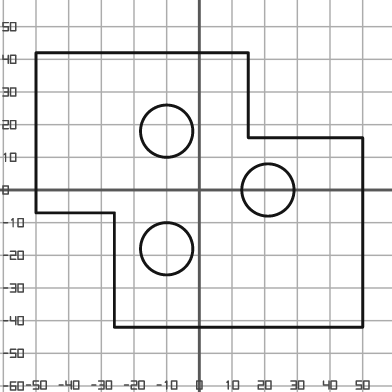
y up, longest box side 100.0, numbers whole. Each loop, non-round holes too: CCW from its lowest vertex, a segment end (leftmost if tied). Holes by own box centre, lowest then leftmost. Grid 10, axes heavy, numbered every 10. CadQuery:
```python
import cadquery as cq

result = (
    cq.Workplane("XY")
    .moveTo(-26.0, -42.0)
    .lineTo(50.0, -42.0)
    .lineTo(50.0, 16.0)
    .lineTo(15.0, 16.0)
    .lineTo(15.0, 42.0)
    .lineTo(-50.0, 42.0)
    .lineTo(-50.0, -7.0)
    .lineTo(-26.0, -7.0)
    .close()
    .moveTo(-10.0, -18.0)
    .circle(8.0)
    .moveTo(21.0, 0.0)
    .circle(8.0)
    .moveTo(-10.0, 18.0)
    .circle(8.0)
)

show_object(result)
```